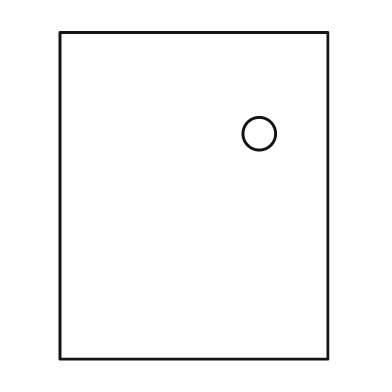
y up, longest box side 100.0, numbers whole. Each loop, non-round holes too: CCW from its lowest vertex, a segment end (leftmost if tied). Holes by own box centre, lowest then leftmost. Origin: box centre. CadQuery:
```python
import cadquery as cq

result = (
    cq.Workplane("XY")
    .moveTo(-41.0, -50.0)
    .lineTo(41.0, -50.0)
    .lineTo(41.0, 50.0)
    .lineTo(-41.0, 50.0)
    .close()
    .moveTo(20.0, 19.0)
    .circle(5.0)
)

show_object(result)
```